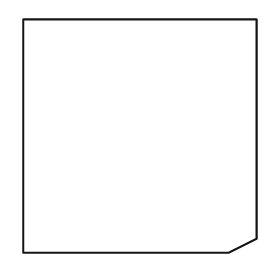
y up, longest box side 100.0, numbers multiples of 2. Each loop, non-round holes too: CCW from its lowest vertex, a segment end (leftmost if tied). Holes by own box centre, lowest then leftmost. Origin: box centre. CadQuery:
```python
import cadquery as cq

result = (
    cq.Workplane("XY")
    .moveTo(-50.0, -50.0)
    .lineTo(38.0, -50.0)
    .lineTo(50.0, -44.0)
    .lineTo(50.0, 50.0)
    .lineTo(-50.0, 50.0)
    .close()
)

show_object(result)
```